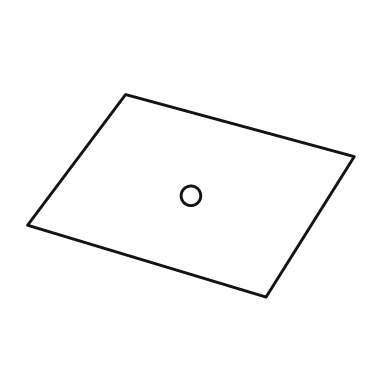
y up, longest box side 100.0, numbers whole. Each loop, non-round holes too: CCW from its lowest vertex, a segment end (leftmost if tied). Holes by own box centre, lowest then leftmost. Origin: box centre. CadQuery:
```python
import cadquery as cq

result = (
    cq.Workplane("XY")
    .moveTo(23.0, -31.0)
    .lineTo(50.0, 12.0)
    .lineTo(-20.0, 31.0)
    .lineTo(-50.0, -9.0)
    .close()
    .moveTo(0.0, 0.0)
    .circle(3.0)
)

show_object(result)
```